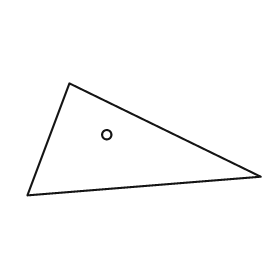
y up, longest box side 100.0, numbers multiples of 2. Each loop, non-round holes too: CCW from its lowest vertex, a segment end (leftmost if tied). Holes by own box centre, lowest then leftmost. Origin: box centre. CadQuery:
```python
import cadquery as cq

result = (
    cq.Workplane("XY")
    .moveTo(-50.0, -24.0)
    .lineTo(50.0, -16.0)
    .lineTo(-32.0, 24.0)
    .close()
    .moveTo(-16.0, 2.0)
    .circle(2.0)
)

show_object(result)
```